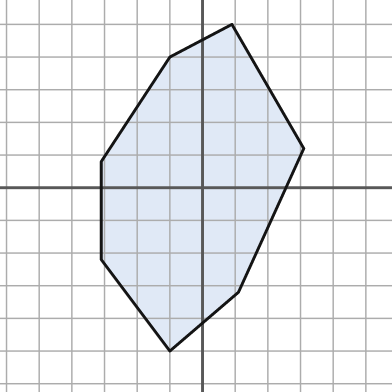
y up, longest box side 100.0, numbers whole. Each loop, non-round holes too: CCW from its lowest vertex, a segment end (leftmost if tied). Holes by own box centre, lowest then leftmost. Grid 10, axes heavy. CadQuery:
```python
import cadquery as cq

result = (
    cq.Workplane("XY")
    .moveTo(-10.0, -50.0)
    .lineTo(11.0, -32.0)
    .lineTo(31.0, 12.0)
    .lineTo(9.0, 50.0)
    .lineTo(-10.0, 40.0)
    .lineTo(-31.0, 8.0)
    .lineTo(-31.0, -22.0)
    .close()
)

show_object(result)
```